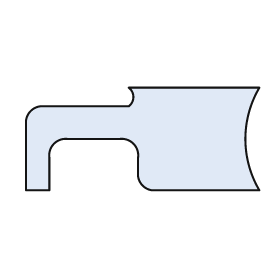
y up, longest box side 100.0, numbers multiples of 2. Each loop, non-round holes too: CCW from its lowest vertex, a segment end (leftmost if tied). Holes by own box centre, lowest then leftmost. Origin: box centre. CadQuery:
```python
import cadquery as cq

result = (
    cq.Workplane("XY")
    .moveTo(-50.0, -22.0)
    .lineTo(-40.0, -22.0)
    .lineTo(-40.0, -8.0)
    .threePointArc((-38.0, -2.0), (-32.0, 0.0))
    .lineTo(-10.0, 0.0)
    .threePointArc((-4.0, -2.0), (-2.0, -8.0))
    .lineTo(-2.0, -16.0)
    .threePointArc((0.0, -20.0), (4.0, -22.0))
    .lineTo(50.0, -22.0)
    .threePointArc((44.0, 0.0), (50.0, 22.0))
    .lineTo(-6.0, 22.0)
    .threePointArc((-4.0, 18.0), (-6.0, 14.0))
    .lineTo(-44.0, 14.0)
    .threePointArc((-48.0, 12.0), (-50.0, 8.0))
    .close()
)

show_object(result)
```